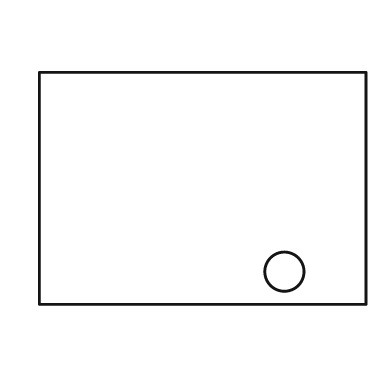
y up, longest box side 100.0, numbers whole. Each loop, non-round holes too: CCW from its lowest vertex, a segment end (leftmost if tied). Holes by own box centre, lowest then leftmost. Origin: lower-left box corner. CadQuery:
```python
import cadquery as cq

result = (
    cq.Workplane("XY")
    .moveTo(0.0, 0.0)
    .lineTo(100.0, 0.0)
    .lineTo(100.0, 71.0)
    .lineTo(0.0, 71.0)
    .close()
    .moveTo(75.0, 10.0)
    .circle(6.0)
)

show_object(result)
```